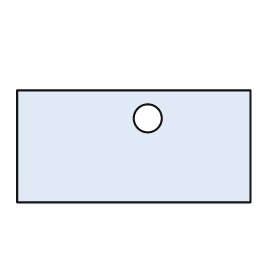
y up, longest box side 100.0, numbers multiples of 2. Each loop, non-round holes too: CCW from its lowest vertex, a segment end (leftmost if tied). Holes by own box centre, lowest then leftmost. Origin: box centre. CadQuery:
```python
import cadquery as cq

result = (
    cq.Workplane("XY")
    .moveTo(-50.0, -24.0)
    .lineTo(50.0, -24.0)
    .lineTo(50.0, 24.0)
    .lineTo(-50.0, 24.0)
    .close()
    .moveTo(6.0, 12.0)
    .circle(6.0)
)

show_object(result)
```